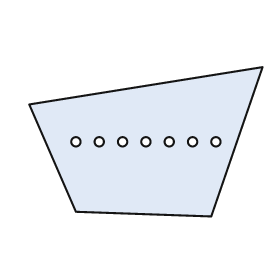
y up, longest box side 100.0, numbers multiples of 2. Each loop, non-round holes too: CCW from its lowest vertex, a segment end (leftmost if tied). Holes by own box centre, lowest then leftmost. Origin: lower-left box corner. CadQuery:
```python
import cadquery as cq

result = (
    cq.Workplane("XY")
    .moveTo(78.0, 0.0)
    .lineTo(100.0, 64.0)
    .lineTo(0.0, 48.0)
    .lineTo(20.0, 2.0)
    .close()
    .moveTo(20.0, 32.0)
    .circle(2.0)
    .moveTo(30.0, 32.0)
    .circle(2.0)
    .moveTo(40.0, 32.0)
    .circle(2.0)
    .moveTo(50.0, 32.0)
    .circle(2.0)
    .moveTo(60.0, 32.0)
    .circle(2.0)
    .moveTo(70.0, 32.0)
    .circle(2.0)
    .moveTo(80.0, 32.0)
    .circle(2.0)
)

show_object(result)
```